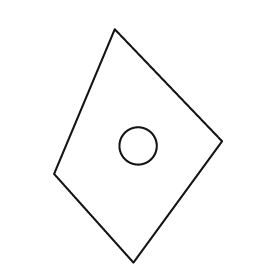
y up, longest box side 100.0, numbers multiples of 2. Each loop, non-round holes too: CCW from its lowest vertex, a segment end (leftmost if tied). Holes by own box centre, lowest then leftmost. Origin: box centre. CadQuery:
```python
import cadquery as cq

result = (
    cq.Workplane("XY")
    .moveTo(-2.0, -50.0)
    .lineTo(36.0, 2.0)
    .lineTo(-10.0, 50.0)
    .lineTo(-36.0, -12.0)
    .close()
    .moveTo(0.0, 0.0)
    .circle(8.0)
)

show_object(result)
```